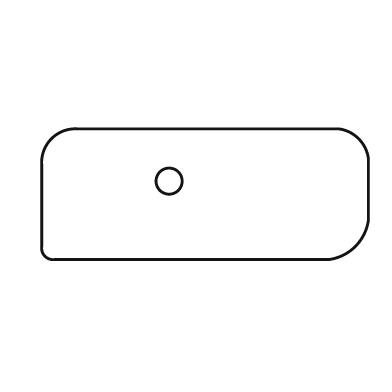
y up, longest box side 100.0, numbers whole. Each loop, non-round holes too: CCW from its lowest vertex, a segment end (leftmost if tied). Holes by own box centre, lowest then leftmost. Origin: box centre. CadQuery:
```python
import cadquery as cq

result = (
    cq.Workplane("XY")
    .moveTo(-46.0, -20.0)
    .lineTo(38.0, -20.0)
    .threePointArc((46.0, -16.0), (50.0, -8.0))
    .lineTo(50.0, 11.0)
    .threePointArc((47.0, 17.0), (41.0, 20.0))
    .lineTo(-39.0, 20.0)
    .threePointArc((-47.0, 17.0), (-50.0, 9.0))
    .lineTo(-50.0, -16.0)
    .threePointArc((-49.0, -19.0), (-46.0, -20.0))
    .close()
    .moveTo(-11.0, 4.0)
    .circle(4.0)
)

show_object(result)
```